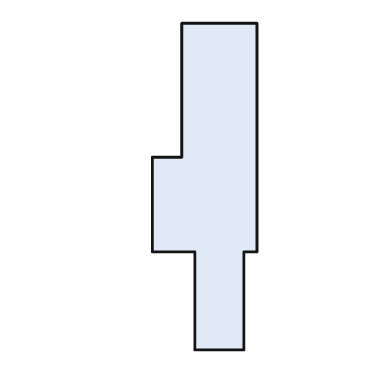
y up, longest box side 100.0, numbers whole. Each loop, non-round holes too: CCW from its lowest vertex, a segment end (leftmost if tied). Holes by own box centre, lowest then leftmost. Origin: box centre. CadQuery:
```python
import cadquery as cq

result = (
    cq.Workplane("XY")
    .moveTo(-3.0, -50.0)
    .lineTo(12.0, -50.0)
    .lineTo(12.0, -20.0)
    .lineTo(16.0, -20.0)
    .lineTo(16.0, 50.0)
    .lineTo(-7.0, 50.0)
    .lineTo(-7.0, 9.0)
    .lineTo(-16.0, 9.0)
    .lineTo(-16.0, -20.0)
    .lineTo(-3.0, -20.0)
    .close()
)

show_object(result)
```